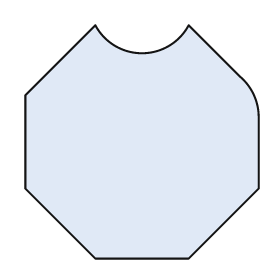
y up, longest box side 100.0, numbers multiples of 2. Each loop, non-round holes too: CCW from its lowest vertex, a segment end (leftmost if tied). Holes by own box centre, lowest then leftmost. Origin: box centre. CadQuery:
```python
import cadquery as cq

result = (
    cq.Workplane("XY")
    .moveTo(-20.0, -50.0)
    .lineTo(20.0, -50.0)
    .lineTo(50.0, -20.0)
    .lineTo(50.0, 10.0)
    .threePointArc((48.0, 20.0), (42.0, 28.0))
    .lineTo(20.0, 50.0)
    .threePointArc((0.0, 38.0), (-20.0, 50.0))
    .lineTo(-50.0, 20.0)
    .lineTo(-50.0, -20.0)
    .close()
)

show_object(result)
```